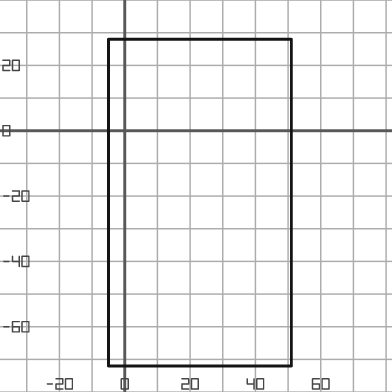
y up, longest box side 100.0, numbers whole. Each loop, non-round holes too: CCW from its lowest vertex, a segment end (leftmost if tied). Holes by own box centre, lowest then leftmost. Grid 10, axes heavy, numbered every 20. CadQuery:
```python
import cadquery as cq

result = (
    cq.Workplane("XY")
    .moveTo(-5.0, -72.0)
    .lineTo(51.0, -72.0)
    .lineTo(51.0, 28.0)
    .lineTo(-5.0, 28.0)
    .close()
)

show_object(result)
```